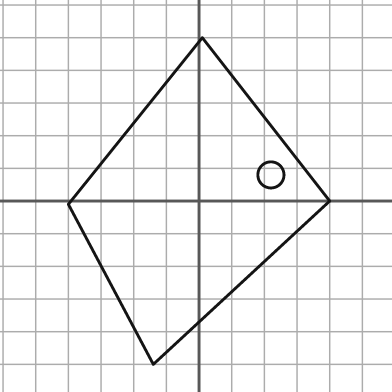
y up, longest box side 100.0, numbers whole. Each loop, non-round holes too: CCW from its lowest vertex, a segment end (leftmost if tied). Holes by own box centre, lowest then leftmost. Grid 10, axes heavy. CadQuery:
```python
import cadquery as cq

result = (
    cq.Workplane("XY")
    .moveTo(-14.0, -50.0)
    .lineTo(40.0, 0.0)
    .lineTo(1.0, 50.0)
    .lineTo(-40.0, -1.0)
    .close()
    .moveTo(22.0, 8.0)
    .circle(4.0)
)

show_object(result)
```